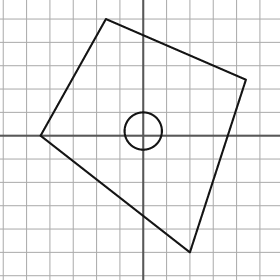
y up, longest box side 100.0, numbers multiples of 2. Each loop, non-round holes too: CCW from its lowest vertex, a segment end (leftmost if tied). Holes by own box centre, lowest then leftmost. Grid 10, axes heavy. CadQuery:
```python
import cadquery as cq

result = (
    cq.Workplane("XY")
    .moveTo(20.0, -50.0)
    .lineTo(44.0, 24.0)
    .lineTo(-16.0, 50.0)
    .lineTo(-44.0, 0.0)
    .close()
    .moveTo(0.0, 2.0)
    .circle(8.0)
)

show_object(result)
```